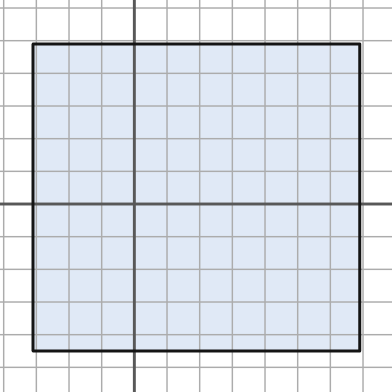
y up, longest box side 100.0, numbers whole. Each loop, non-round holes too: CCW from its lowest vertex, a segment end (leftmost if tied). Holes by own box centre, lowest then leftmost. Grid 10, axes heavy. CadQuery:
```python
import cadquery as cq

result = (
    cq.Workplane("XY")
    .moveTo(-31.0, -45.0)
    .lineTo(69.0, -45.0)
    .lineTo(69.0, 49.0)
    .lineTo(-31.0, 49.0)
    .close()
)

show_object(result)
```